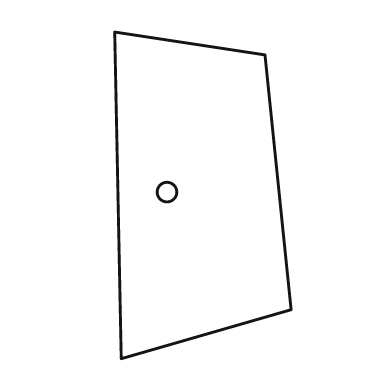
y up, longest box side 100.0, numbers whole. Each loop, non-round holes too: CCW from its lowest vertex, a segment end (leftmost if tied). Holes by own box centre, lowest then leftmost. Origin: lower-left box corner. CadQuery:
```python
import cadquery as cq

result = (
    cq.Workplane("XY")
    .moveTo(2.0, 0.0)
    .lineTo(54.0, 15.0)
    .lineTo(46.0, 93.0)
    .lineTo(0.0, 100.0)
    .close()
    .moveTo(16.0, 51.0)
    .circle(3.0)
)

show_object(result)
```